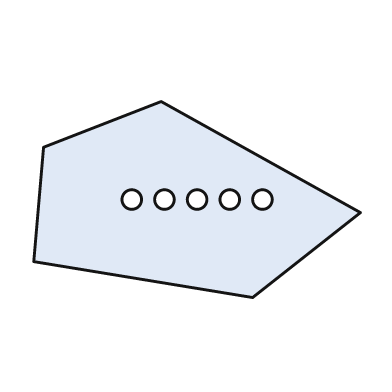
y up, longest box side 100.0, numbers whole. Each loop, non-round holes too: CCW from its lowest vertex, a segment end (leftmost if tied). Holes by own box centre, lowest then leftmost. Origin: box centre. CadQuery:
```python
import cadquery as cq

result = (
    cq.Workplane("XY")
    .moveTo(17.0, -30.0)
    .lineTo(50.0, -4.0)
    .lineTo(-11.0, 30.0)
    .lineTo(-47.0, 16.0)
    .lineTo(-50.0, -19.0)
    .close()
    .moveTo(-20.0, 0.0)
    .circle(3.0)
    .moveTo(-10.0, 0.0)
    .circle(3.0)
    .moveTo(0.0, 0.0)
    .circle(3.0)
    .moveTo(10.0, 0.0)
    .circle(3.0)
    .moveTo(20.0, 0.0)
    .circle(3.0)
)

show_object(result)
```